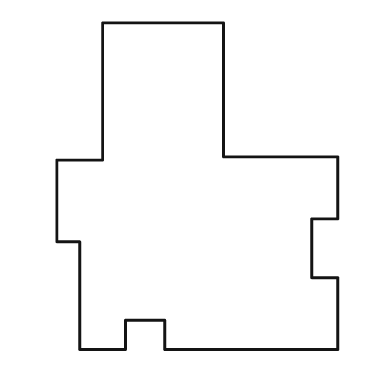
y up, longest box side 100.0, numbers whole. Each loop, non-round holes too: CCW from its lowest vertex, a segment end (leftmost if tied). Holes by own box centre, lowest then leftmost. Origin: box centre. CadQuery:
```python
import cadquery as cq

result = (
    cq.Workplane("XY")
    .moveTo(-36.0, -50.0)
    .lineTo(-22.0, -50.0)
    .lineTo(-22.0, -41.0)
    .lineTo(-10.0, -41.0)
    .lineTo(-10.0, -50.0)
    .lineTo(43.0, -50.0)
    .lineTo(43.0, -28.0)
    .lineTo(35.0, -28.0)
    .lineTo(35.0, -10.0)
    .lineTo(43.0, -10.0)
    .lineTo(43.0, 9.0)
    .lineTo(8.0, 9.0)
    .lineTo(8.0, 50.0)
    .lineTo(-29.0, 50.0)
    .lineTo(-29.0, 8.0)
    .lineTo(-43.0, 8.0)
    .lineTo(-43.0, -17.0)
    .lineTo(-36.0, -17.0)
    .close()
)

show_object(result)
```